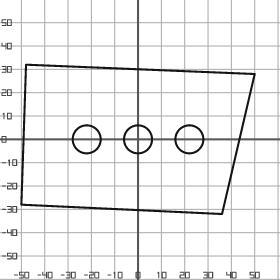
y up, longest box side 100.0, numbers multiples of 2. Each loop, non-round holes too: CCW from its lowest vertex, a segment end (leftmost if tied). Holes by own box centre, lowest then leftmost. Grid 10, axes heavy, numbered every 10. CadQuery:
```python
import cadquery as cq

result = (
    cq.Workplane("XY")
    .moveTo(36.0, -32.0)
    .lineTo(50.0, 28.0)
    .lineTo(-48.0, 32.0)
    .lineTo(-50.0, -28.0)
    .close()
    .moveTo(-22.0, 0.0)
    .circle(6.0)
    .moveTo(0.0, 0.0)
    .circle(6.0)
    .moveTo(22.0, 0.0)
    .circle(6.0)
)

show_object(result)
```